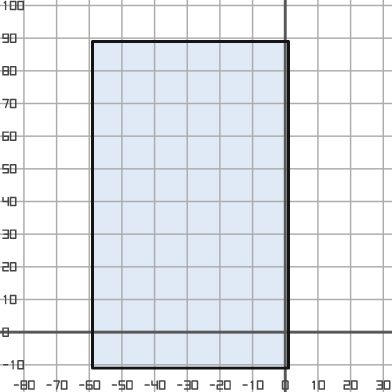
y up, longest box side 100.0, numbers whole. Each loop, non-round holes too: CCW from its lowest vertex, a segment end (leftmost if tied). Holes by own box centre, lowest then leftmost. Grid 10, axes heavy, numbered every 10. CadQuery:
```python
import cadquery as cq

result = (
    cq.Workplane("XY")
    .moveTo(-59.0, -11.0)
    .lineTo(1.0, -11.0)
    .lineTo(1.0, 89.0)
    .lineTo(-59.0, 89.0)
    .close()
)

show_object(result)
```